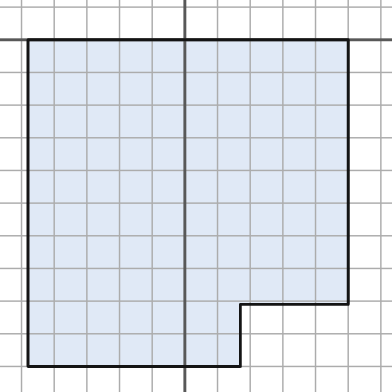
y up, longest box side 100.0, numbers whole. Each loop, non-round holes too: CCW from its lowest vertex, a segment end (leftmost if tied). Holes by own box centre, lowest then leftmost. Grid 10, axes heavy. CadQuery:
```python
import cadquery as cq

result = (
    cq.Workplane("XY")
    .moveTo(-48.0, -100.0)
    .lineTo(17.0, -100.0)
    .lineTo(17.0, -81.0)
    .lineTo(50.0, -81.0)
    .lineTo(50.0, 0.0)
    .lineTo(-48.0, 0.0)
    .close()
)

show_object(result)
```